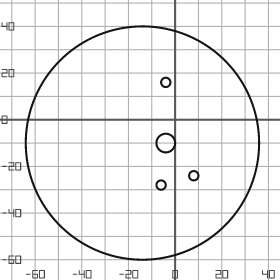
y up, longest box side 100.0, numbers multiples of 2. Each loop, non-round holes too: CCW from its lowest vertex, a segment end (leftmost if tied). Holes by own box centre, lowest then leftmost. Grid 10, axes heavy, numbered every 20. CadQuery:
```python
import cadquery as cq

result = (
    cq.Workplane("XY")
    .moveTo(-14.0, -10.0)
    .circle(50.0)
    .moveTo(-6.0, -28.0)
    .circle(2.0)
    .moveTo(8.0, -24.0)
    .circle(2.0)
    .moveTo(-4.0, -10.0)
    .circle(4.0)
    .moveTo(-4.0, 16.0)
    .circle(2.0)
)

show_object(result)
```